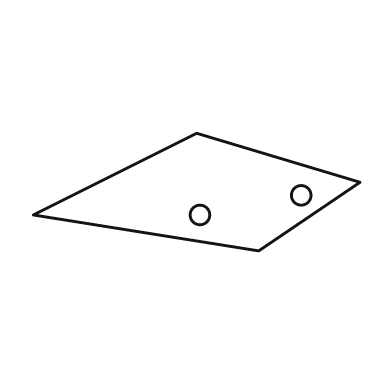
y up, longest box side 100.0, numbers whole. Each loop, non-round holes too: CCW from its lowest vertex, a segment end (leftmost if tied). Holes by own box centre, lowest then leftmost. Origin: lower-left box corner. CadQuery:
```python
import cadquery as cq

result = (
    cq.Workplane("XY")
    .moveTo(69.0, 0.0)
    .lineTo(100.0, 21.0)
    .lineTo(50.0, 36.0)
    .lineTo(0.0, 11.0)
    .close()
    .moveTo(51.0, 11.0)
    .circle(3.0)
    .moveTo(82.0, 17.0)
    .circle(3.0)
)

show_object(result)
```